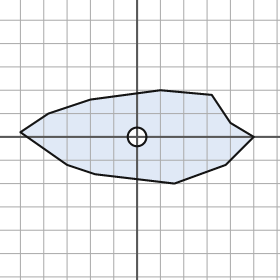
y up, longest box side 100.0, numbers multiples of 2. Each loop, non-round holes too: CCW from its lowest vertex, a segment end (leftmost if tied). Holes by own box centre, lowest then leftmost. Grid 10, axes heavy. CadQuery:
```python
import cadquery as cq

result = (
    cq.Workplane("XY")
    .moveTo(16.0, -20.0)
    .lineTo(38.0, -12.0)
    .lineTo(50.0, 0.0)
    .lineTo(40.0, 6.0)
    .lineTo(32.0, 18.0)
    .lineTo(10.0, 20.0)
    .lineTo(-20.0, 16.0)
    .lineTo(-38.0, 10.0)
    .lineTo(-50.0, 2.0)
    .lineTo(-30.0, -12.0)
    .lineTo(-18.0, -16.0)
    .close()
    .moveTo(0.0, 0.0)
    .circle(4.0)
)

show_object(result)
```